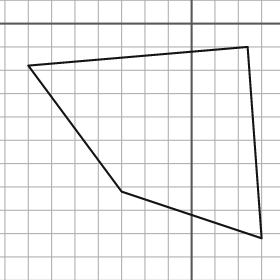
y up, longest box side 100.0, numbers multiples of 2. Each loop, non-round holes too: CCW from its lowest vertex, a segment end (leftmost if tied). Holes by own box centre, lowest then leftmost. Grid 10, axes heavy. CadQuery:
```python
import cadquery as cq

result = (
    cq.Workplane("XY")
    .moveTo(30.0, -92.0)
    .lineTo(24.0, -10.0)
    .lineTo(-70.0, -18.0)
    .lineTo(-30.0, -72.0)
    .close()
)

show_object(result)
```